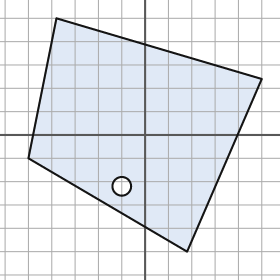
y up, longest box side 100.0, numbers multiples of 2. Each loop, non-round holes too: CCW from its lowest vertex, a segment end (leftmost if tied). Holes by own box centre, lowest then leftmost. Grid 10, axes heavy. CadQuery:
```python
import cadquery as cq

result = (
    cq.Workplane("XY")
    .moveTo(18.0, -50.0)
    .lineTo(50.0, 24.0)
    .lineTo(-38.0, 50.0)
    .lineTo(-50.0, -10.0)
    .close()
    .moveTo(-10.0, -22.0)
    .circle(4.0)
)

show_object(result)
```